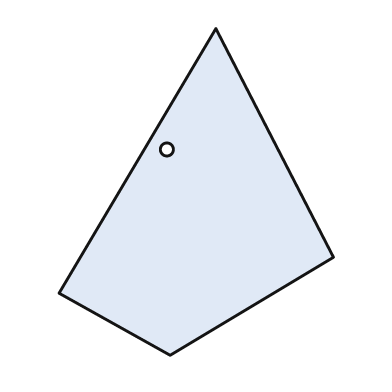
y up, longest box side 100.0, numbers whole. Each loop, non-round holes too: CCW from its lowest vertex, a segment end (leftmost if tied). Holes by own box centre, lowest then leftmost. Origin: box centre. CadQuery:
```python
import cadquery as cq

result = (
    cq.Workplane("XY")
    .moveTo(-8.0, -50.0)
    .lineTo(42.0, -20.0)
    .lineTo(6.0, 50.0)
    .lineTo(-42.0, -31.0)
    .close()
    .moveTo(-9.0, 13.0)
    .circle(2.0)
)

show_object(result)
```